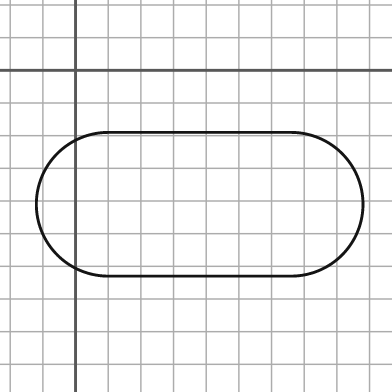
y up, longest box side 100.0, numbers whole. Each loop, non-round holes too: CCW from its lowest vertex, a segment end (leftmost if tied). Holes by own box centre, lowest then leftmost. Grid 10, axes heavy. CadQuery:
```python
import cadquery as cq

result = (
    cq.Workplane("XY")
    .moveTo(10.0, -63.0)
    .lineTo(66.0, -63.0)
    .threePointArc((88.0, -41.0), (66.0, -19.0))
    .lineTo(10.0, -19.0)
    .threePointArc((-12.0, -41.0), (10.0, -63.0))
    .close()
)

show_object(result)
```